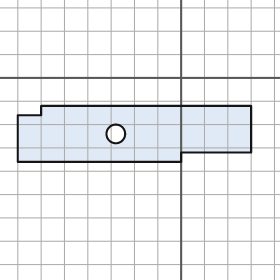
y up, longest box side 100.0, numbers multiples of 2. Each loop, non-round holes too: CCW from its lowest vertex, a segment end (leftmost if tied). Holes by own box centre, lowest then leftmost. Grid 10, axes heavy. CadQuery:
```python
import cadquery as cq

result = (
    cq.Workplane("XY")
    .moveTo(-70.0, -36.0)
    .lineTo(0.0, -36.0)
    .lineTo(0.0, -32.0)
    .lineTo(30.0, -32.0)
    .lineTo(30.0, -12.0)
    .lineTo(-60.0, -12.0)
    .lineTo(-60.0, -16.0)
    .lineTo(-70.0, -16.0)
    .close()
    .moveTo(-28.0, -24.0)
    .circle(4.0)
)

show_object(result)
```